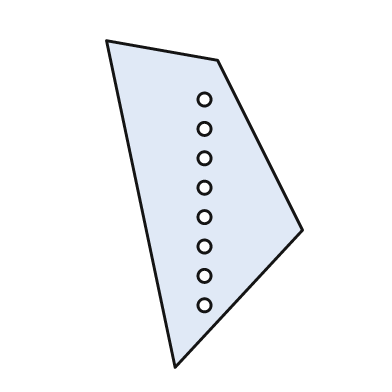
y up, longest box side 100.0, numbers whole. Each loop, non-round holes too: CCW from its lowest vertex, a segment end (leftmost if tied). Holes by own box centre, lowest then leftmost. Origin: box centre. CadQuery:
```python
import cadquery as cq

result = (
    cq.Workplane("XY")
    .moveTo(-9.0, -50.0)
    .lineTo(30.0, -8.0)
    .lineTo(4.0, 44.0)
    .lineTo(-30.0, 50.0)
    .close()
    .moveTo(0.0, -31.0)
    .circle(2.0)
    .moveTo(0.0, -22.0)
    .circle(2.0)
    .moveTo(0.0, -13.0)
    .circle(2.0)
    .moveTo(0.0, -4.0)
    .circle(2.0)
    .moveTo(0.0, 5.0)
    .circle(2.0)
    .moveTo(0.0, 14.0)
    .circle(2.0)
    .moveTo(0.0, 23.0)
    .circle(2.0)
    .moveTo(0.0, 32.0)
    .circle(2.0)
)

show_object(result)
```